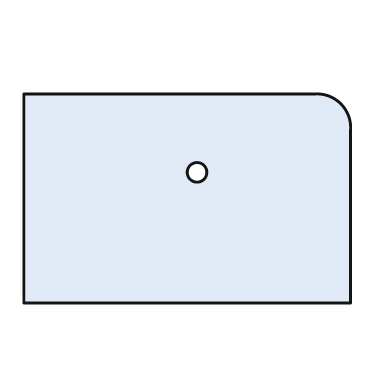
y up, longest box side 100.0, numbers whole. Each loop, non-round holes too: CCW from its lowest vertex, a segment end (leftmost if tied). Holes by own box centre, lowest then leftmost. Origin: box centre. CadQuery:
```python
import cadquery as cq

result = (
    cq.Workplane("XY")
    .moveTo(-50.0, -32.0)
    .lineTo(50.0, -32.0)
    .lineTo(50.0, 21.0)
    .threePointArc((47.0, 29.0), (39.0, 32.0))
    .lineTo(-50.0, 32.0)
    .close()
    .moveTo(3.0, 8.0)
    .circle(3.0)
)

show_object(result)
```